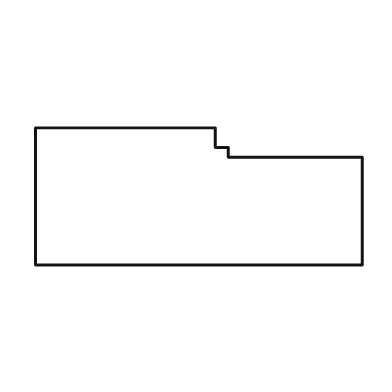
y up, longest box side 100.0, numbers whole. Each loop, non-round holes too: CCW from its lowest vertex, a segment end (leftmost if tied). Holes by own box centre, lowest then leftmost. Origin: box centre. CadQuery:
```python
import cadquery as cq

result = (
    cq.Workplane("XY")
    .moveTo(-50.0, -21.0)
    .lineTo(50.0, -21.0)
    .lineTo(50.0, 12.0)
    .lineTo(9.0, 12.0)
    .lineTo(9.0, 15.0)
    .lineTo(5.0, 15.0)
    .lineTo(5.0, 21.0)
    .lineTo(-50.0, 21.0)
    .close()
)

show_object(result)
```